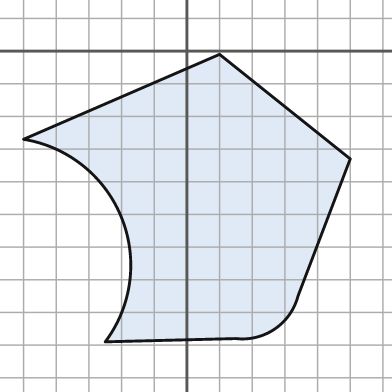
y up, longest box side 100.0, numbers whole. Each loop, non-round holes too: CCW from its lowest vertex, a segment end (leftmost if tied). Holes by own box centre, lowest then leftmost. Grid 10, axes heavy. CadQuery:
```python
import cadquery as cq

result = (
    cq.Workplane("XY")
    .moveTo(-25.0, -89.0)
    .lineTo(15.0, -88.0)
    .threePointArc((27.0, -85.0), (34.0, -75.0))
    .lineTo(50.0, -33.0)
    .lineTo(10.0, -1.0)
    .lineTo(-50.0, -27.0)
    .threePointArc((-20.0, -51.0), (-25.0, -89.0))
    .close()
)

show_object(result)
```